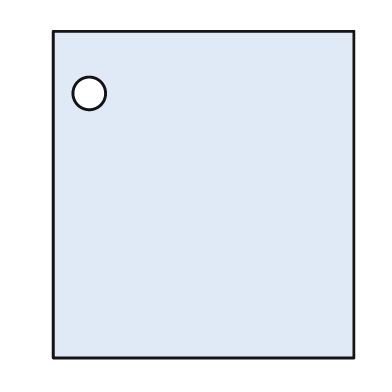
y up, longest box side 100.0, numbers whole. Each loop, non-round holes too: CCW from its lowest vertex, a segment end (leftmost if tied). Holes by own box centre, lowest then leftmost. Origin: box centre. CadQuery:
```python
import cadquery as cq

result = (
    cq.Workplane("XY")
    .moveTo(-46.0, -50.0)
    .lineTo(46.0, -50.0)
    .lineTo(46.0, 50.0)
    .lineTo(-46.0, 50.0)
    .close()
    .moveTo(-35.0, 31.0)
    .circle(5.0)
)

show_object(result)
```